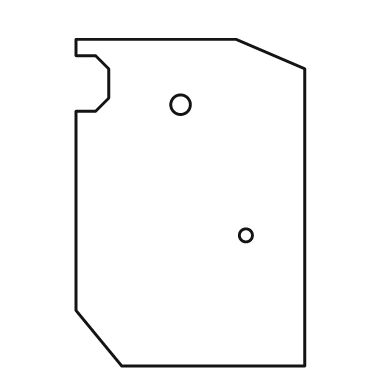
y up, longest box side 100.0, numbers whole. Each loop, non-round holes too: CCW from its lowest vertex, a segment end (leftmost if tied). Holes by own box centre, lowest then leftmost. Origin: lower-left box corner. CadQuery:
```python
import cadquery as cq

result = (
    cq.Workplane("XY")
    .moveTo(14.0, 0.0)
    .lineTo(70.0, 0.0)
    .lineTo(70.0, 91.0)
    .lineTo(49.0, 100.0)
    .lineTo(0.0, 100.0)
    .lineTo(0.0, 95.0)
    .lineTo(6.0, 95.0)
    .lineTo(10.0, 91.0)
    .lineTo(10.0, 82.0)
    .lineTo(6.0, 78.0)
    .lineTo(0.0, 78.0)
    .lineTo(0.0, 17.0)
    .close()
    .moveTo(52.0, 40.0)
    .circle(2.0)
    .moveTo(32.0, 80.0)
    .circle(3.0)
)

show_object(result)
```